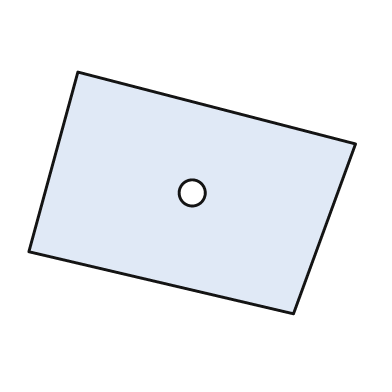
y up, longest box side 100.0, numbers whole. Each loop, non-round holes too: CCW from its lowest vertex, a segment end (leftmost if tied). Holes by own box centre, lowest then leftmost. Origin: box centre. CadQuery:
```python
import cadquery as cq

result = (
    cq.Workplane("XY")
    .moveTo(31.0, -37.0)
    .lineTo(50.0, 15.0)
    .lineTo(-35.0, 37.0)
    .lineTo(-50.0, -18.0)
    .close()
    .moveTo(0.0, 0.0)
    .circle(4.0)
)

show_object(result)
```